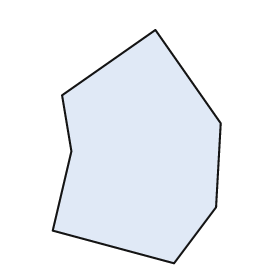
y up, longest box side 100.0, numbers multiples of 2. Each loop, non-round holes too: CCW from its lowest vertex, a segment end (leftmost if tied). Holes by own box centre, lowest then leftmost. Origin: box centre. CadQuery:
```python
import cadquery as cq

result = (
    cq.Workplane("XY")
    .moveTo(16.0, -50.0)
    .lineTo(34.0, -26.0)
    .lineTo(36.0, 10.0)
    .lineTo(8.0, 50.0)
    .lineTo(-32.0, 22.0)
    .lineTo(-28.0, -2.0)
    .lineTo(-36.0, -36.0)
    .close()
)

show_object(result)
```